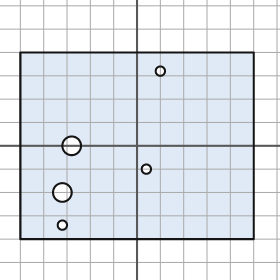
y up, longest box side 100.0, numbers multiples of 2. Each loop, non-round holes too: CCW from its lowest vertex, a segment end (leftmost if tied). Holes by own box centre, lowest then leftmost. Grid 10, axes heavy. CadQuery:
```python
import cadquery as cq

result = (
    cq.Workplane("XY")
    .moveTo(-50.0, -40.0)
    .lineTo(50.0, -40.0)
    .lineTo(50.0, 40.0)
    .lineTo(-50.0, 40.0)
    .close()
    .moveTo(-32.0, -34.0)
    .circle(2.0)
    .moveTo(-32.0, -20.0)
    .circle(4.0)
    .moveTo(4.0, -10.0)
    .circle(2.0)
    .moveTo(-28.0, 0.0)
    .circle(4.0)
    .moveTo(10.0, 32.0)
    .circle(2.0)
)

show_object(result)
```